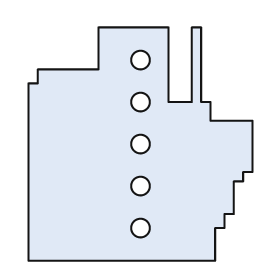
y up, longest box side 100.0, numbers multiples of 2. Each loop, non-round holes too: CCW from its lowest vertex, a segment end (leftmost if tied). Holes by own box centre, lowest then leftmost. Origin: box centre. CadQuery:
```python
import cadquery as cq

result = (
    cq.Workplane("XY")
    .moveTo(-48.0, -50.0)
    .lineTo(32.0, -50.0)
    .lineTo(32.0, -36.0)
    .lineTo(36.0, -36.0)
    .lineTo(36.0, -30.0)
    .lineTo(40.0, -30.0)
    .lineTo(40.0, -16.0)
    .lineTo(44.0, -16.0)
    .lineTo(44.0, -12.0)
    .lineTo(48.0, -12.0)
    .lineTo(48.0, 10.0)
    .lineTo(30.0, 10.0)
    .lineTo(30.0, 18.0)
    .lineTo(26.0, 18.0)
    .lineTo(26.0, 50.0)
    .lineTo(22.0, 50.0)
    .lineTo(22.0, 18.0)
    .lineTo(12.0, 18.0)
    .lineTo(12.0, 50.0)
    .lineTo(-18.0, 50.0)
    .lineTo(-18.0, 32.0)
    .lineTo(-44.0, 32.0)
    .lineTo(-44.0, 26.0)
    .lineTo(-48.0, 26.0)
    .close()
    .moveTo(0.0, -36.0)
    .circle(4.0)
    .moveTo(0.0, -18.0)
    .circle(4.0)
    .moveTo(0.0, 0.0)
    .circle(4.0)
    .moveTo(0.0, 18.0)
    .circle(4.0)
    .moveTo(0.0, 36.0)
    .circle(4.0)
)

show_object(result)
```